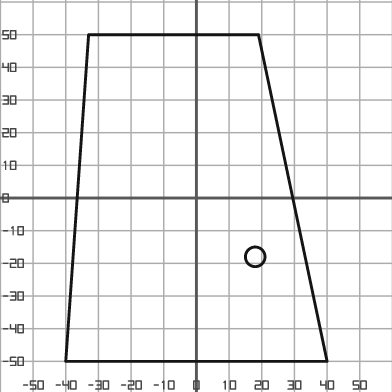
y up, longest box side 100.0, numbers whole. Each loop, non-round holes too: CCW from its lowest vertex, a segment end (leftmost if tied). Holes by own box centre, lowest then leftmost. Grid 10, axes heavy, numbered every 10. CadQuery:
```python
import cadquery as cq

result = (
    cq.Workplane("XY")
    .moveTo(-40.0, -50.0)
    .lineTo(40.0, -50.0)
    .lineTo(19.0, 50.0)
    .lineTo(-33.0, 50.0)
    .close()
    .moveTo(18.0, -18.0)
    .circle(3.0)
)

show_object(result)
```